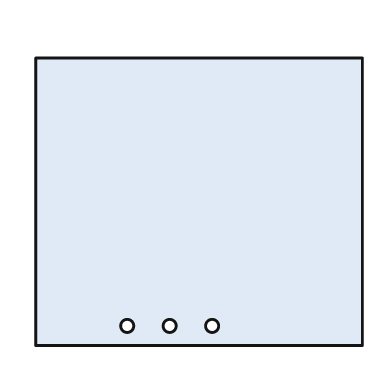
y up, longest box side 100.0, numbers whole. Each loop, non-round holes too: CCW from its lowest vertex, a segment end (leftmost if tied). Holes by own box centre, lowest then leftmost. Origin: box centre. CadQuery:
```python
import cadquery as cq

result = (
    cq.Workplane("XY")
    .moveTo(-50.0, -44.0)
    .lineTo(50.0, -44.0)
    .lineTo(50.0, 44.0)
    .lineTo(-50.0, 44.0)
    .close()
    .moveTo(-22.0, -38.0)
    .circle(2.0)
    .moveTo(-9.0, -38.0)
    .circle(2.0)
    .moveTo(4.0, -38.0)
    .circle(2.0)
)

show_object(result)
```